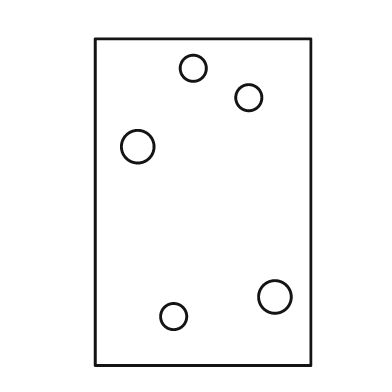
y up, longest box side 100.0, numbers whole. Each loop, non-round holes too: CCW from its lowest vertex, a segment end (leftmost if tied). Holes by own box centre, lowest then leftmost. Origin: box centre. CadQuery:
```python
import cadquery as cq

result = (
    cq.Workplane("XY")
    .moveTo(-33.0, -50.0)
    .lineTo(33.0, -50.0)
    .lineTo(33.0, 50.0)
    .lineTo(-33.0, 50.0)
    .close()
    .moveTo(-9.0, -35.0)
    .circle(4.0)
    .moveTo(22.0, -29.0)
    .circle(5.0)
    .moveTo(-20.0, 17.0)
    .circle(5.0)
    .moveTo(14.0, 32.0)
    .circle(4.0)
    .moveTo(-3.0, 41.0)
    .circle(4.0)
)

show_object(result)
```